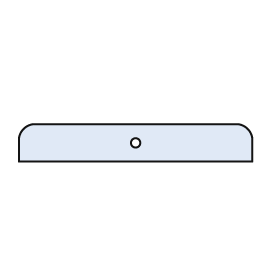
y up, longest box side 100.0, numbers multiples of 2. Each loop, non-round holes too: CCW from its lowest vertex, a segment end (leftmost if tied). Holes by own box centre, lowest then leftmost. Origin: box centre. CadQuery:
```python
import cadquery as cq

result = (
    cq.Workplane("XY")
    .moveTo(-50.0, -8.0)
    .lineTo(50.0, -8.0)
    .lineTo(50.0, 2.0)
    .threePointArc((48.0, 6.0), (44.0, 8.0))
    .lineTo(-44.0, 8.0)
    .threePointArc((-48.0, 6.0), (-50.0, 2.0))
    .close()
    .moveTo(0.0, 0.0)
    .circle(2.0)
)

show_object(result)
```